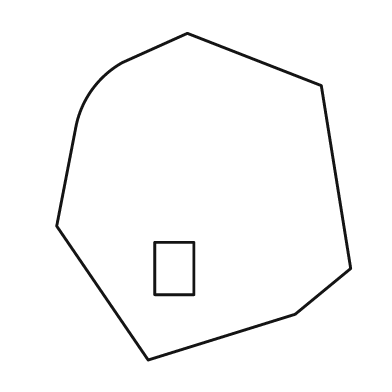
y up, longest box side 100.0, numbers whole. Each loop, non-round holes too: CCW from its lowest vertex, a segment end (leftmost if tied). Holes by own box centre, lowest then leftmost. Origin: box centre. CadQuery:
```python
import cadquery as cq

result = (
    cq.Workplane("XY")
    .moveTo(-17.0, -50.0)
    .lineTo(28.0, -36.0)
    .lineTo(45.0, -22.0)
    .lineTo(36.0, 34.0)
    .lineTo(-5.0, 50.0)
    .lineTo(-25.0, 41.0)
    .threePointArc((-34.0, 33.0), (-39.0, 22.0))
    .lineTo(-45.0, -9.0)
    .close()
    .moveTo(-15.0, -30.0)
    .lineTo(-3.0, -30.0)
    .lineTo(-3.0, -14.0)
    .lineTo(-15.0, -14.0)
    .close()
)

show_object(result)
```